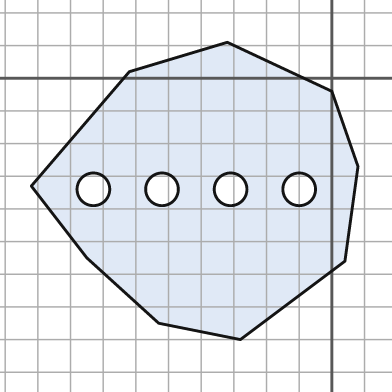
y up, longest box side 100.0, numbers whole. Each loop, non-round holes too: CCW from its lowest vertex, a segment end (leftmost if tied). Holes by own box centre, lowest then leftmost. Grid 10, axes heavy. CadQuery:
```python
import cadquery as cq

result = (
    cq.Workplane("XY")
    .moveTo(-28.0, -80.0)
    .lineTo(4.0, -56.0)
    .lineTo(8.0, -27.0)
    .lineTo(0.0, -4.0)
    .lineTo(-32.0, 11.0)
    .lineTo(-62.0, 2.0)
    .lineTo(-92.0, -33.0)
    .lineTo(-75.0, -55.0)
    .lineTo(-53.0, -75.0)
    .close()
    .moveTo(-73.0, -34.0)
    .circle(5.0)
    .moveTo(-52.0, -34.0)
    .circle(5.0)
    .moveTo(-31.0, -34.0)
    .circle(5.0)
    .moveTo(-10.0, -34.0)
    .circle(5.0)
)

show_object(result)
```